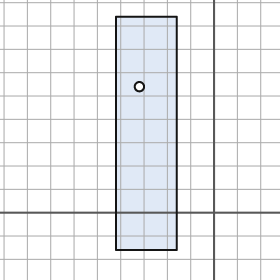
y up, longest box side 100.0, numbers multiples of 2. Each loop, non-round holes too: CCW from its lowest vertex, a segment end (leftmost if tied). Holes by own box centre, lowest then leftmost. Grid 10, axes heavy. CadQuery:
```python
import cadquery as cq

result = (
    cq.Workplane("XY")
    .moveTo(-42.0, -16.0)
    .lineTo(-16.0, -16.0)
    .lineTo(-16.0, 84.0)
    .lineTo(-42.0, 84.0)
    .close()
    .moveTo(-32.0, 54.0)
    .circle(2.0)
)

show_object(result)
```